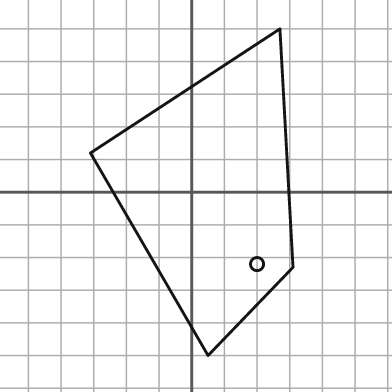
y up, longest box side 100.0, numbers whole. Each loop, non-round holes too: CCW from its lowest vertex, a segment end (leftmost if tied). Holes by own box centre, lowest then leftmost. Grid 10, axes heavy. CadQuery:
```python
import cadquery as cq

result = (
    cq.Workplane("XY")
    .moveTo(5.0, -50.0)
    .lineTo(31.0, -23.0)
    .lineTo(27.0, 50.0)
    .lineTo(-31.0, 12.0)
    .close()
    .moveTo(20.0, -22.0)
    .circle(2.0)
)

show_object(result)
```